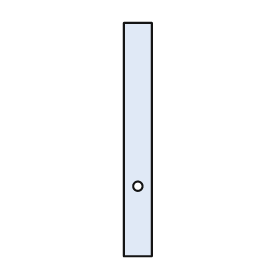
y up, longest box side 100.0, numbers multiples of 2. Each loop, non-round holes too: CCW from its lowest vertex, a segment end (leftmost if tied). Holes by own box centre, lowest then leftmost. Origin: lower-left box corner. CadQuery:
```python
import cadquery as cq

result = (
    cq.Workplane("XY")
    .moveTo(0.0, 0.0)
    .lineTo(12.0, 0.0)
    .lineTo(12.0, 100.0)
    .lineTo(0.0, 100.0)
    .close()
    .moveTo(6.0, 30.0)
    .circle(2.0)
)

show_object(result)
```